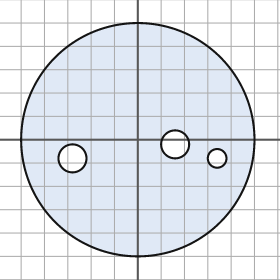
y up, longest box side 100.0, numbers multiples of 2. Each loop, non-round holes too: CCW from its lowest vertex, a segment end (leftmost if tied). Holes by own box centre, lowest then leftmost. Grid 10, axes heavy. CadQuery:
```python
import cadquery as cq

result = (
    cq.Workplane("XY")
    .moveTo(0.0, 0.0)
    .circle(50.0)
    .moveTo(-28.0, -8.0)
    .circle(6.0)
    .moveTo(34.0, -8.0)
    .circle(4.0)
    .moveTo(16.0, -2.0)
    .circle(6.0)
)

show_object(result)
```